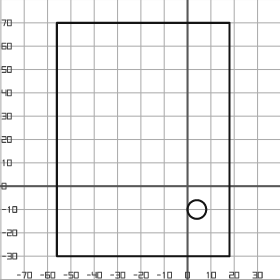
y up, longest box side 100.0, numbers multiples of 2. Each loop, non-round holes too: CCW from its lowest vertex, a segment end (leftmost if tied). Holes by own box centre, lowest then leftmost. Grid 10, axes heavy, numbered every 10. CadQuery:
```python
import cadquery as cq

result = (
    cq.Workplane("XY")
    .moveTo(-56.0, -30.0)
    .lineTo(18.0, -30.0)
    .lineTo(18.0, 70.0)
    .lineTo(-56.0, 70.0)
    .close()
    .moveTo(4.0, -10.0)
    .circle(4.0)
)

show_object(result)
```